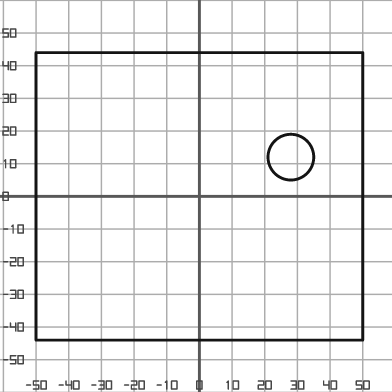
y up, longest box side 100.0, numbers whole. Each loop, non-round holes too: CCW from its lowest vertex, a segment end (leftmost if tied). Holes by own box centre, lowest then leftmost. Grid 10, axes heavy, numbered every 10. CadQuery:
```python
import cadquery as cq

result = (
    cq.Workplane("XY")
    .moveTo(-50.0, -44.0)
    .lineTo(50.0, -44.0)
    .lineTo(50.0, 44.0)
    .lineTo(-50.0, 44.0)
    .close()
    .moveTo(28.0, 12.0)
    .circle(7.0)
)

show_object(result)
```